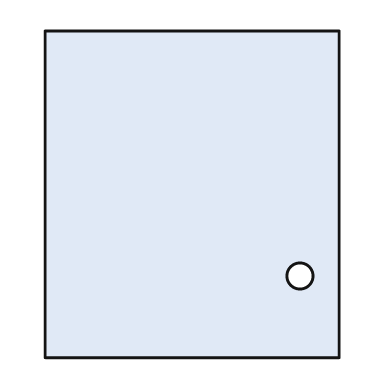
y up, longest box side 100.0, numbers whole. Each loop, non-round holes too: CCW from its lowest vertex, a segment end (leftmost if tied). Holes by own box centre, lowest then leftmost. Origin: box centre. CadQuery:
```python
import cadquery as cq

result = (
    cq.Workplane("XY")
    .moveTo(-45.0, -50.0)
    .lineTo(45.0, -50.0)
    .lineTo(45.0, 50.0)
    .lineTo(-45.0, 50.0)
    .close()
    .moveTo(33.0, -25.0)
    .circle(4.0)
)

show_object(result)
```